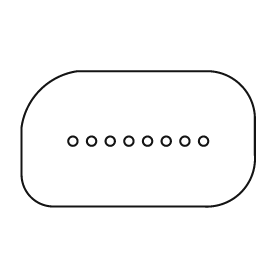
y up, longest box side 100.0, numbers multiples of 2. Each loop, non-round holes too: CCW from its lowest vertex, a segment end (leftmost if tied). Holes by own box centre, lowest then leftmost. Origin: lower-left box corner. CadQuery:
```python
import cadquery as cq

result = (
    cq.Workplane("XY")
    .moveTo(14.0, 0.0)
    .lineTo(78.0, 0.0)
    .threePointArc((94.0, 6.0), (100.0, 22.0))
    .lineTo(100.0, 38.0)
    .threePointArc((94.0, 52.0), (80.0, 58.0))
    .lineTo(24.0, 58.0)
    .threePointArc((8.0, 50.0), (0.0, 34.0))
    .lineTo(0.0, 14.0)
    .threePointArc((4.0, 4.0), (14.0, 0.0))
    .close()
    .moveTo(22.0, 28.0)
    .circle(2.0)
    .moveTo(30.0, 28.0)
    .circle(2.0)
    .moveTo(38.0, 28.0)
    .circle(2.0)
    .moveTo(46.0, 28.0)
    .circle(2.0)
    .moveTo(54.0, 28.0)
    .circle(2.0)
    .moveTo(62.0, 28.0)
    .circle(2.0)
    .moveTo(70.0, 28.0)
    .circle(2.0)
    .moveTo(78.0, 28.0)
    .circle(2.0)
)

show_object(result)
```